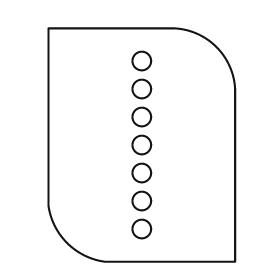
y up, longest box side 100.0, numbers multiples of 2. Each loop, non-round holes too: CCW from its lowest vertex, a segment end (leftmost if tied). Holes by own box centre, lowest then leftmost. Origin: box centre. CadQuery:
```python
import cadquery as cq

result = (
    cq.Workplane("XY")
    .moveTo(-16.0, -50.0)
    .lineTo(40.0, -50.0)
    .lineTo(40.0, 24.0)
    .threePointArc((32.0, 42.0), (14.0, 50.0))
    .lineTo(-40.0, 50.0)
    .lineTo(-40.0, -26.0)
    .threePointArc((-32.0, -42.0), (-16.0, -50.0))
    .close()
    .moveTo(0.0, -36.0)
    .circle(4.0)
    .moveTo(0.0, -24.0)
    .circle(4.0)
    .moveTo(0.0, -12.0)
    .circle(4.0)
    .moveTo(0.0, 0.0)
    .circle(4.0)
    .moveTo(0.0, 12.0)
    .circle(4.0)
    .moveTo(0.0, 24.0)
    .circle(4.0)
    .moveTo(0.0, 36.0)
    .circle(4.0)
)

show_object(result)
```